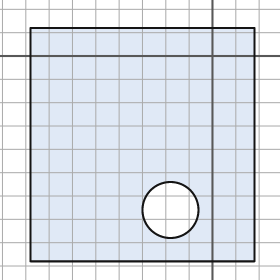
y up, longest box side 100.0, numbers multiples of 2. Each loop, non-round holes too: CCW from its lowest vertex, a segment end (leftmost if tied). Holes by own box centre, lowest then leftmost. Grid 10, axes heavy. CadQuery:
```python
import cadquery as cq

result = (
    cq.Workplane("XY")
    .moveTo(-78.0, -88.0)
    .lineTo(18.0, -88.0)
    .lineTo(18.0, 12.0)
    .lineTo(-78.0, 12.0)
    .close()
    .moveTo(-18.0, -66.0)
    .circle(12.0)
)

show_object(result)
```